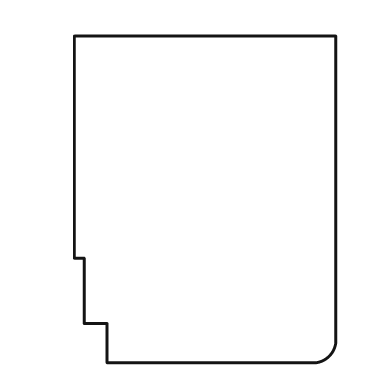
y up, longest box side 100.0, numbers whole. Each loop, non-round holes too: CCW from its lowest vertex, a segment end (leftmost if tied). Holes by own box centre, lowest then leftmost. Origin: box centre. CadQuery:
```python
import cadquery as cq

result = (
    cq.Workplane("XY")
    .moveTo(-30.0, -50.0)
    .lineTo(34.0, -50.0)
    .threePointArc((38.0, -48.0), (40.0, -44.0))
    .lineTo(40.0, 50.0)
    .lineTo(-40.0, 50.0)
    .lineTo(-40.0, -18.0)
    .lineTo(-37.0, -18.0)
    .lineTo(-37.0, -38.0)
    .lineTo(-30.0, -38.0)
    .close()
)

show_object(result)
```